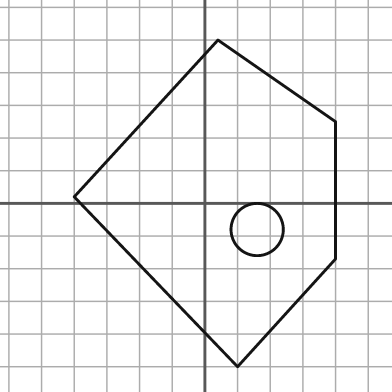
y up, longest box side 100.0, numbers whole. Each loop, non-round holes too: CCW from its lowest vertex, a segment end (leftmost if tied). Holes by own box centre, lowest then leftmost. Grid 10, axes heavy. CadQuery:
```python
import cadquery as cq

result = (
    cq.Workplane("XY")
    .moveTo(10.0, -50.0)
    .lineTo(40.0, -17.0)
    .lineTo(40.0, 25.0)
    .lineTo(4.0, 50.0)
    .lineTo(-40.0, 2.0)
    .close()
    .moveTo(16.0, -8.0)
    .circle(8.0)
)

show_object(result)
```